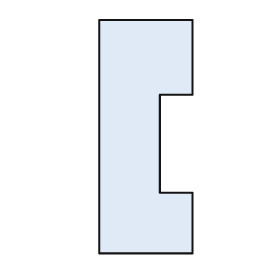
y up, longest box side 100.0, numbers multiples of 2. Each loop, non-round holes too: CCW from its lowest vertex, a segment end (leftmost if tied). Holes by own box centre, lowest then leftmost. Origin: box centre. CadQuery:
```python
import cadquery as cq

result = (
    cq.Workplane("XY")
    .moveTo(-20.0, -50.0)
    .lineTo(20.0, -50.0)
    .lineTo(20.0, -24.0)
    .lineTo(6.0, -24.0)
    .lineTo(6.0, 18.0)
    .lineTo(20.0, 18.0)
    .lineTo(20.0, 50.0)
    .lineTo(-20.0, 50.0)
    .close()
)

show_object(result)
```